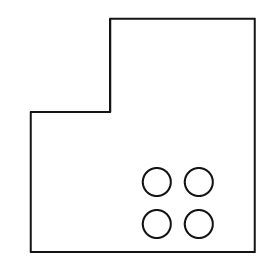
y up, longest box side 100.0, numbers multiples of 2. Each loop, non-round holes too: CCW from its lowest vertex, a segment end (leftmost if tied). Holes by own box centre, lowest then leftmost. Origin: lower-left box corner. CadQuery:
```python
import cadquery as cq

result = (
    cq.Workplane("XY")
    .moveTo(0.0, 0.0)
    .lineTo(96.0, 0.0)
    .lineTo(96.0, 100.0)
    .lineTo(34.0, 100.0)
    .lineTo(34.0, 60.0)
    .lineTo(0.0, 60.0)
    .close()
    .moveTo(54.0, 12.0)
    .circle(6.0)
    .moveTo(72.0, 12.0)
    .circle(6.0)
    .moveTo(54.0, 30.0)
    .circle(6.0)
    .moveTo(72.0, 30.0)
    .circle(6.0)
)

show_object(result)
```